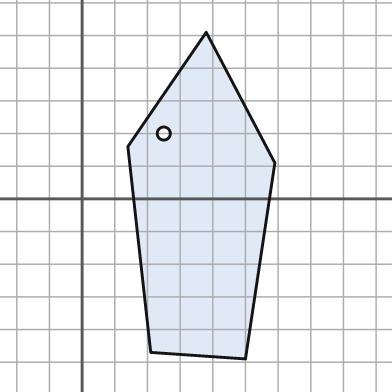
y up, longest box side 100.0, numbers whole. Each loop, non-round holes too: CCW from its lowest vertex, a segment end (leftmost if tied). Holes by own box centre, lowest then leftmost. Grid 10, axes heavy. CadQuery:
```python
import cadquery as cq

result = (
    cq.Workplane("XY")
    .moveTo(50.0, -49.0)
    .lineTo(59.0, 11.0)
    .lineTo(38.0, 51.0)
    .lineTo(14.0, 16.0)
    .lineTo(21.0, -47.0)
    .close()
    .moveTo(25.0, 20.0)
    .circle(2.0)
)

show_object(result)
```